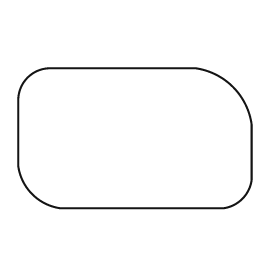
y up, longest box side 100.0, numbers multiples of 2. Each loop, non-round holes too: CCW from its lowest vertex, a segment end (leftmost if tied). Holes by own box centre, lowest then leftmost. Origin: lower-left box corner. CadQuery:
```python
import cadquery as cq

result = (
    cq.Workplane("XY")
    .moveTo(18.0, 0.0)
    .lineTo(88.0, 0.0)
    .threePointArc((96.0, 4.0), (100.0, 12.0))
    .lineTo(100.0, 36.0)
    .threePointArc((92.0, 52.0), (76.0, 60.0))
    .lineTo(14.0, 60.0)
    .threePointArc((4.0, 56.0), (0.0, 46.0))
    .lineTo(0.0, 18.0)
    .threePointArc((6.0, 6.0), (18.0, 0.0))
    .close()
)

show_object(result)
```